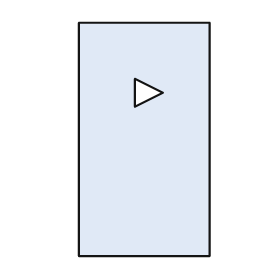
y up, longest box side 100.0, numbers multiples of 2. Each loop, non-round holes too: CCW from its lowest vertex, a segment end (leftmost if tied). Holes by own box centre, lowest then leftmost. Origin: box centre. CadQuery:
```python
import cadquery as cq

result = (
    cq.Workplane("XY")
    .moveTo(-28.0, -50.0)
    .lineTo(28.0, -50.0)
    .lineTo(28.0, 50.0)
    .lineTo(-28.0, 50.0)
    .close()
    .moveTo(-4.0, 14.0)
    .lineTo(8.0, 20.0)
    .lineTo(-4.0, 26.0)
    .close()
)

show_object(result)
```